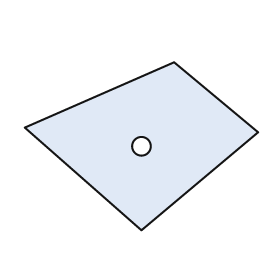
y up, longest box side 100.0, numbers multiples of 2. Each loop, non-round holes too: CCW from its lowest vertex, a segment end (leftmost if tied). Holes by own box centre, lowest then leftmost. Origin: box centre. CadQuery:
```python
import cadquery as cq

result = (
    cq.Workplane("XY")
    .moveTo(0.0, -36.0)
    .lineTo(50.0, 6.0)
    .lineTo(14.0, 36.0)
    .lineTo(-50.0, 8.0)
    .close()
    .moveTo(0.0, 0.0)
    .circle(4.0)
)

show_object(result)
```